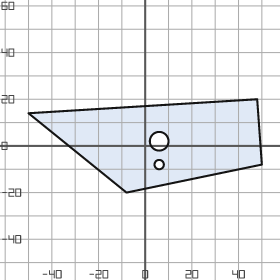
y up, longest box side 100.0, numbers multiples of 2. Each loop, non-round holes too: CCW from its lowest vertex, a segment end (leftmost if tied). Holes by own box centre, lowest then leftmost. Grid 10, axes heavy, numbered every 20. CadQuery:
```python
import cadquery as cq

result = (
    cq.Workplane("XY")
    .moveTo(-8.0, -20.0)
    .lineTo(50.0, -8.0)
    .lineTo(48.0, 20.0)
    .lineTo(-50.0, 14.0)
    .close()
    .moveTo(6.0, -8.0)
    .circle(2.0)
    .moveTo(6.0, 2.0)
    .circle(4.0)
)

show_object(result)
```